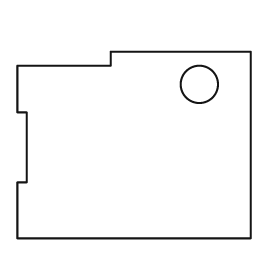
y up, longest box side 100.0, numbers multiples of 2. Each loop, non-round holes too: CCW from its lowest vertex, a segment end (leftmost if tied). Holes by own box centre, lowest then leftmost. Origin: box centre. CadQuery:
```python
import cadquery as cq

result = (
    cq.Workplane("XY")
    .moveTo(-50.0, -40.0)
    .lineTo(50.0, -40.0)
    .lineTo(50.0, 40.0)
    .lineTo(-10.0, 40.0)
    .lineTo(-10.0, 34.0)
    .lineTo(-50.0, 34.0)
    .lineTo(-50.0, 14.0)
    .lineTo(-46.0, 14.0)
    .lineTo(-46.0, -16.0)
    .lineTo(-50.0, -16.0)
    .close()
    .moveTo(28.0, 26.0)
    .circle(8.0)
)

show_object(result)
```